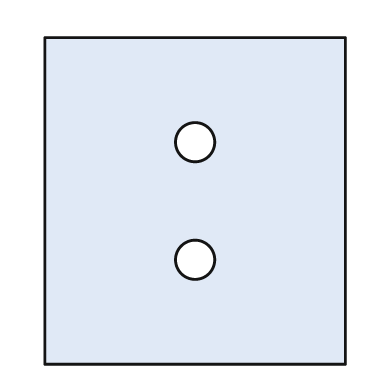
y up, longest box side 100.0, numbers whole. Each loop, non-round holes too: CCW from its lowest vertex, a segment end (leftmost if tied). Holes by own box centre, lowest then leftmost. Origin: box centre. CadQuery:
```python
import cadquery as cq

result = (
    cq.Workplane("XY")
    .moveTo(-46.0, -50.0)
    .lineTo(46.0, -50.0)
    .lineTo(46.0, 50.0)
    .lineTo(-46.0, 50.0)
    .close()
    .moveTo(0.0, -18.0)
    .circle(6.0)
    .moveTo(0.0, 18.0)
    .circle(6.0)
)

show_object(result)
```